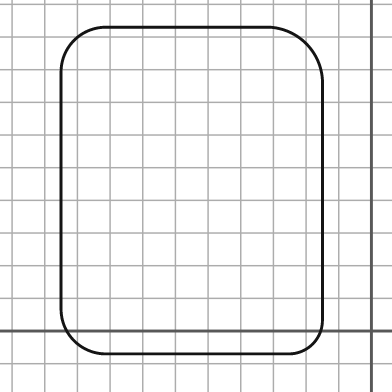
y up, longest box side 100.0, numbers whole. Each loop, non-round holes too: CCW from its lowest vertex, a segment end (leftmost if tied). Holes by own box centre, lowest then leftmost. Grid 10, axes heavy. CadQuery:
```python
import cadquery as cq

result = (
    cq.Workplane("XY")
    .moveTo(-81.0, -7.0)
    .lineTo(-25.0, -7.0)
    .threePointArc((-18.0, -4.0), (-15.0, 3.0))
    .lineTo(-15.0, 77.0)
    .threePointArc((-20.0, 88.0), (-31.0, 93.0))
    .lineTo(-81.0, 93.0)
    .threePointArc((-91.0, 89.0), (-95.0, 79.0))
    .lineTo(-95.0, 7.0)
    .threePointArc((-91.0, -3.0), (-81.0, -7.0))
    .close()
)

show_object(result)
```